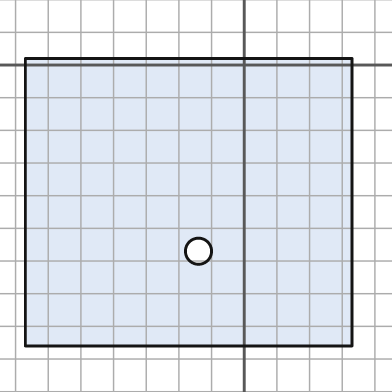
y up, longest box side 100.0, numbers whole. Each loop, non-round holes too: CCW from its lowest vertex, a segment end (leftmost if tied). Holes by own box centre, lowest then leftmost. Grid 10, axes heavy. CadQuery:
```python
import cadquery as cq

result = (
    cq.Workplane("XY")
    .moveTo(-67.0, -86.0)
    .lineTo(33.0, -86.0)
    .lineTo(33.0, 2.0)
    .lineTo(-67.0, 2.0)
    .close()
    .moveTo(-14.0, -57.0)
    .circle(4.0)
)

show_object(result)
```